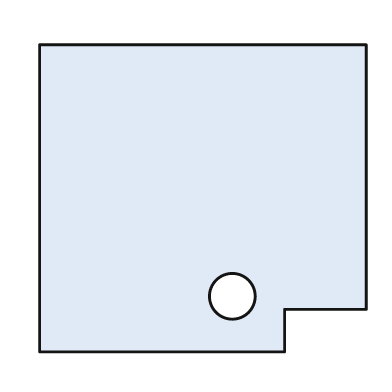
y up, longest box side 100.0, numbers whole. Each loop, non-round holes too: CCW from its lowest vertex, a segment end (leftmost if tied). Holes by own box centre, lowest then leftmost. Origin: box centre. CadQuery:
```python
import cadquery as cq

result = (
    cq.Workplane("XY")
    .moveTo(-50.0, -47.0)
    .lineTo(25.0, -47.0)
    .lineTo(25.0, -34.0)
    .lineTo(50.0, -34.0)
    .lineTo(50.0, 47.0)
    .lineTo(-50.0, 47.0)
    .close()
    .moveTo(9.0, -30.0)
    .circle(7.0)
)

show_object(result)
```